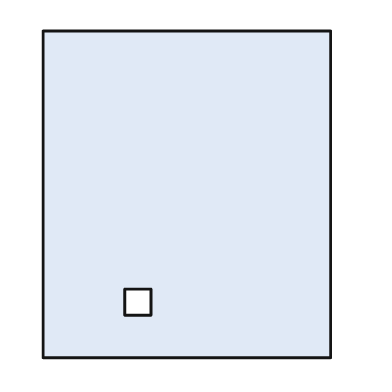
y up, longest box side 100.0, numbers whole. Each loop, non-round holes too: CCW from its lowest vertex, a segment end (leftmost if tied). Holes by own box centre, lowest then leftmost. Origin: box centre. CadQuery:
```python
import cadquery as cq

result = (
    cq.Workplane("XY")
    .moveTo(-44.0, -50.0)
    .lineTo(44.0, -50.0)
    .lineTo(44.0, 50.0)
    .lineTo(-44.0, 50.0)
    .close()
    .moveTo(-19.0, -37.0)
    .lineTo(-11.0, -37.0)
    .lineTo(-11.0, -29.0)
    .lineTo(-19.0, -29.0)
    .close()
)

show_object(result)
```